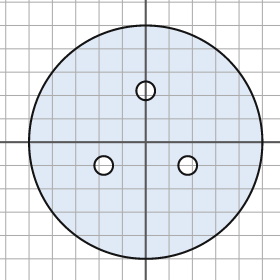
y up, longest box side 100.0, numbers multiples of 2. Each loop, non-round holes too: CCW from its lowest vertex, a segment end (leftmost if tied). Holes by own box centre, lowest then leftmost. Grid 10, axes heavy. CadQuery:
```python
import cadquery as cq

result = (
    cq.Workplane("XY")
    .moveTo(0.0, 0.0)
    .circle(50.0)
    .moveTo(-18.0, -10.0)
    .circle(4.0)
    .moveTo(18.0, -10.0)
    .circle(4.0)
    .moveTo(0.0, 22.0)
    .circle(4.0)
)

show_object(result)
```